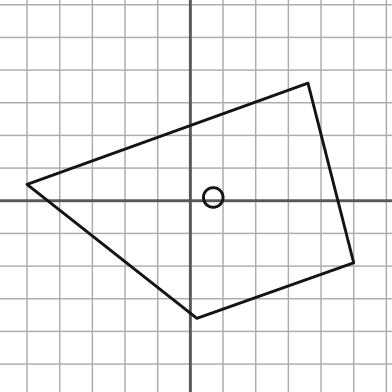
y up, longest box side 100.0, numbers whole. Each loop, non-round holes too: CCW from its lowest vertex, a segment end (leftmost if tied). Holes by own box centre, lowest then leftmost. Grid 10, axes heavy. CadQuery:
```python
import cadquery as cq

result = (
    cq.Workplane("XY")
    .moveTo(2.0, -36.0)
    .lineTo(50.0, -19.0)
    .lineTo(36.0, 36.0)
    .lineTo(-50.0, 5.0)
    .close()
    .moveTo(7.0, 1.0)
    .circle(3.0)
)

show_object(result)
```